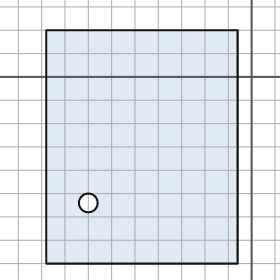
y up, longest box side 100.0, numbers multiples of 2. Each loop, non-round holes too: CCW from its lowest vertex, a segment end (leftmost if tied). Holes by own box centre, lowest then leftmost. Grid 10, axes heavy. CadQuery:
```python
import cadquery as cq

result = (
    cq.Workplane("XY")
    .moveTo(-88.0, -80.0)
    .lineTo(-6.0, -80.0)
    .lineTo(-6.0, 20.0)
    .lineTo(-88.0, 20.0)
    .close()
    .moveTo(-70.0, -54.0)
    .circle(4.0)
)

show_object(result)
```